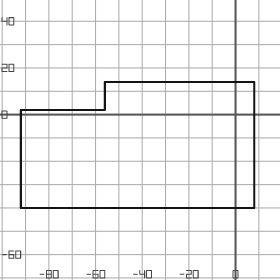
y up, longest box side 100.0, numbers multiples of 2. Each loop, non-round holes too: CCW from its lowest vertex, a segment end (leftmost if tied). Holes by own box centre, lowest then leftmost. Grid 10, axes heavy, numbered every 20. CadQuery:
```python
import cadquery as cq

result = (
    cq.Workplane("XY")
    .moveTo(-92.0, -40.0)
    .lineTo(8.0, -40.0)
    .lineTo(8.0, 14.0)
    .lineTo(-56.0, 14.0)
    .lineTo(-56.0, 2.0)
    .lineTo(-92.0, 2.0)
    .close()
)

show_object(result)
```